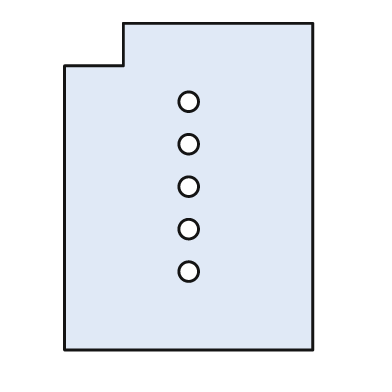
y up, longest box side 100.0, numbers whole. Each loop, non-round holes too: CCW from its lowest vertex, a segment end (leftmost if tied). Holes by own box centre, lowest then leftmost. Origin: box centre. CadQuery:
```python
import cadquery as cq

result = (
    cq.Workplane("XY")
    .moveTo(-38.0, -50.0)
    .lineTo(38.0, -50.0)
    .lineTo(38.0, 50.0)
    .lineTo(-20.0, 50.0)
    .lineTo(-20.0, 37.0)
    .lineTo(-38.0, 37.0)
    .close()
    .moveTo(0.0, -26.0)
    .circle(3.0)
    .moveTo(0.0, -13.0)
    .circle(3.0)
    .moveTo(0.0, 0.0)
    .circle(3.0)
    .moveTo(0.0, 13.0)
    .circle(3.0)
    .moveTo(0.0, 26.0)
    .circle(3.0)
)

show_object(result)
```